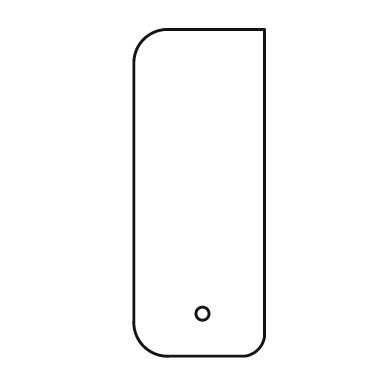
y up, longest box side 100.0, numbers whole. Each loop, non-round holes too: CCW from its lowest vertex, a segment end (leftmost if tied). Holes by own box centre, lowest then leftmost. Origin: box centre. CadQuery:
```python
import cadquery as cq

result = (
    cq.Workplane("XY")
    .moveTo(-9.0, -50.0)
    .lineTo(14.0, -50.0)
    .threePointArc((18.0, -48.0), (20.0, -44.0))
    .lineTo(20.0, 50.0)
    .lineTo(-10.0, 50.0)
    .threePointArc((-17.0, 47.0), (-20.0, 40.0))
    .lineTo(-20.0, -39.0)
    .threePointArc((-17.0, -47.0), (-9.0, -50.0))
    .close()
    .moveTo(1.0, -37.0)
    .circle(2.0)
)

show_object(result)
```